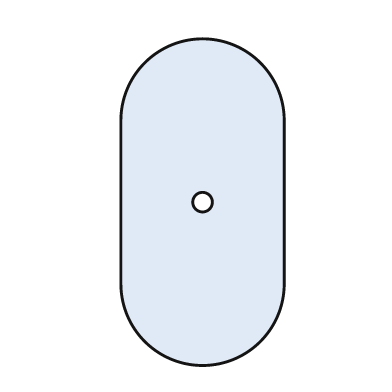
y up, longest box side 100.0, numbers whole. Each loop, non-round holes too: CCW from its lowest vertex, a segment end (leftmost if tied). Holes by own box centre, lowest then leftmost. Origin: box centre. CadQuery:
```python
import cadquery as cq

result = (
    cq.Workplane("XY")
    .moveTo(-25.0, -25.0)
    .threePointArc((0.0, -50.0), (25.0, -25.0))
    .lineTo(25.0, 25.0)
    .threePointArc((0.0, 50.0), (-25.0, 25.0))
    .close()
    .moveTo(0.0, 0.0)
    .circle(3.0)
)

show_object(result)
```